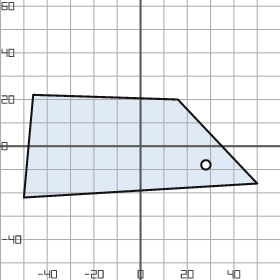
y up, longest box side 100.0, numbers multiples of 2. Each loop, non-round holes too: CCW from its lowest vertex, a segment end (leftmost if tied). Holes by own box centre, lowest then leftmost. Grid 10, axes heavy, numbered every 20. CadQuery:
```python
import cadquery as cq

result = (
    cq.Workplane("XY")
    .moveTo(-50.0, -22.0)
    .lineTo(50.0, -16.0)
    .lineTo(16.0, 20.0)
    .lineTo(-46.0, 22.0)
    .close()
    .moveTo(28.0, -8.0)
    .circle(2.0)
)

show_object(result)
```